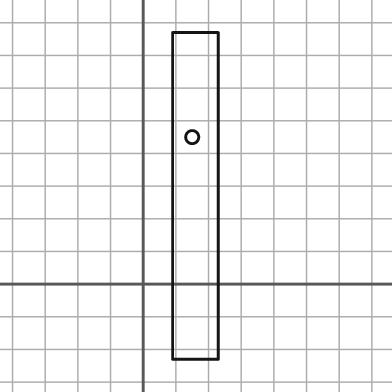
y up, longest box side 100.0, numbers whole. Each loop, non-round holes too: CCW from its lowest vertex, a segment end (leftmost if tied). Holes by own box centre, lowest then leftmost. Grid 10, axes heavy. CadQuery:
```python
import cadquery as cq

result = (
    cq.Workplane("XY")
    .moveTo(9.0, -23.0)
    .lineTo(23.0, -23.0)
    .lineTo(23.0, 77.0)
    .lineTo(9.0, 77.0)
    .close()
    .moveTo(15.0, 45.0)
    .circle(2.0)
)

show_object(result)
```